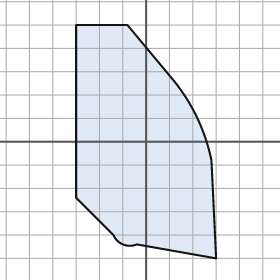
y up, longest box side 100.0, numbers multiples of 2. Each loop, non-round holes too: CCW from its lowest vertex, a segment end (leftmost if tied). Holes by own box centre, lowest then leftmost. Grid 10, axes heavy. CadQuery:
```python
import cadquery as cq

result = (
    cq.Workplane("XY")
    .moveTo(30.0, -50.0)
    .lineTo(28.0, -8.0)
    .threePointArc((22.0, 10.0), (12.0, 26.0))
    .lineTo(-8.0, 50.0)
    .lineTo(-30.0, 50.0)
    .lineTo(-30.0, -24.0)
    .lineTo(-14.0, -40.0)
    .threePointArc((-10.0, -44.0), (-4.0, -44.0))
    .close()
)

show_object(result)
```